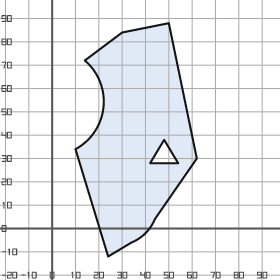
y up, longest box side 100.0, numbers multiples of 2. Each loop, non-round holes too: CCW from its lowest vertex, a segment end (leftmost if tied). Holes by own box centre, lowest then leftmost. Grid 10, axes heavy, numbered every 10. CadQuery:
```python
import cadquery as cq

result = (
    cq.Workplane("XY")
    .moveTo(24.0, -12.0)
    .lineTo(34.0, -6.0)
    .threePointArc((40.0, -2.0), (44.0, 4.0))
    .lineTo(62.0, 30.0)
    .lineTo(50.0, 88.0)
    .lineTo(30.0, 84.0)
    .lineTo(14.0, 72.0)
    .threePointArc((22.0, 52.0), (10.0, 34.0))
    .close()
    .moveTo(42.0, 28.0)
    .lineTo(54.0, 28.0)
    .lineTo(48.0, 38.0)
    .close()
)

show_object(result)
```